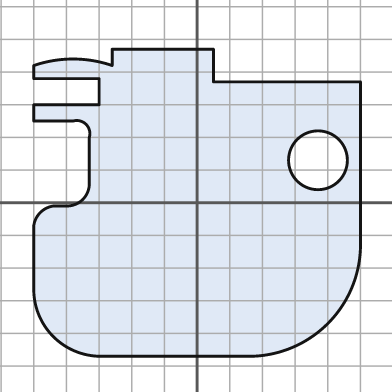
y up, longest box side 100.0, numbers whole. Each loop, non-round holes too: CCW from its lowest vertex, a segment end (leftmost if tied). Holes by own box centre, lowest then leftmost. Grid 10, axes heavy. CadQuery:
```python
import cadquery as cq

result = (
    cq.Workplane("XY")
    .moveTo(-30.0, -47.0)
    .lineTo(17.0, -47.0)
    .threePointArc((40.0, -37.0), (50.0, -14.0))
    .lineTo(50.0, 37.0)
    .lineTo(5.0, 37.0)
    .lineTo(5.0, 47.0)
    .lineTo(-26.0, 47.0)
    .lineTo(-26.0, 42.0)
    .threePointArc((-38.0, 44.0), (-50.0, 42.0))
    .lineTo(-50.0, 38.0)
    .lineTo(-30.0, 38.0)
    .lineTo(-30.0, 30.0)
    .lineTo(-50.0, 30.0)
    .lineTo(-50.0, 25.0)
    .lineTo(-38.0, 25.0)
    .threePointArc((-34.0, 24.0), (-33.0, 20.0))
    .lineTo(-33.0, 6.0)
    .threePointArc((-35.0, 1.0), (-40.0, -1.0))
    .lineTo(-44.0, -1.0)
    .threePointArc((-48.0, -3.0), (-50.0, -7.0))
    .lineTo(-50.0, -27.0)
    .threePointArc((-44.0, -41.0), (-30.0, -47.0))
    .close()
    .moveTo(37.0, 13.0)
    .circle(9.0)
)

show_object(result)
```